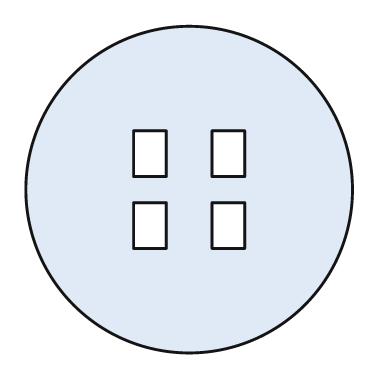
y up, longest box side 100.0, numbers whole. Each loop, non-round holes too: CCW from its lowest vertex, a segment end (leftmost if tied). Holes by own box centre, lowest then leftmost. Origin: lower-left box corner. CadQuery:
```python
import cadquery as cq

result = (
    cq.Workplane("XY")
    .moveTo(50.0, 50.0)
    .circle(50.0)
    .moveTo(33.0, 32.0)
    .lineTo(43.0, 32.0)
    .lineTo(43.0, 46.0)
    .lineTo(33.0, 46.0)
    .close()
    .moveTo(57.0, 32.0)
    .lineTo(67.0, 32.0)
    .lineTo(67.0, 46.0)
    .lineTo(57.0, 46.0)
    .close()
    .moveTo(33.0, 54.0)
    .lineTo(43.0, 54.0)
    .lineTo(43.0, 68.0)
    .lineTo(33.0, 68.0)
    .close()
    .moveTo(57.0, 54.0)
    .lineTo(67.0, 54.0)
    .lineTo(67.0, 68.0)
    .lineTo(57.0, 68.0)
    .close()
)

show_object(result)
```